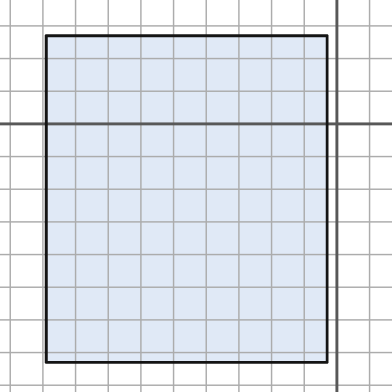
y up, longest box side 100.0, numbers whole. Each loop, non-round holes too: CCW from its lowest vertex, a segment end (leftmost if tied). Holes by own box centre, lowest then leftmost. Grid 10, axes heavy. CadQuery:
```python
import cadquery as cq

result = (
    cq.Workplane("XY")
    .moveTo(-89.0, -73.0)
    .lineTo(-3.0, -73.0)
    .lineTo(-3.0, 27.0)
    .lineTo(-89.0, 27.0)
    .close()
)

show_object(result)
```